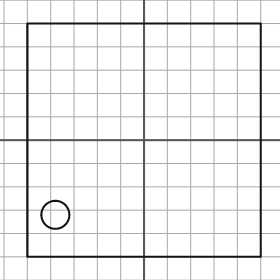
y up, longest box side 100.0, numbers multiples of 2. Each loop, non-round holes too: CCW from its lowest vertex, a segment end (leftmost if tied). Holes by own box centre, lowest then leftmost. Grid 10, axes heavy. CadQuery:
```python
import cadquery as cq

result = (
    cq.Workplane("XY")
    .moveTo(-50.0, -50.0)
    .lineTo(50.0, -50.0)
    .lineTo(50.0, 50.0)
    .lineTo(-50.0, 50.0)
    .close()
    .moveTo(-38.0, -32.0)
    .circle(6.0)
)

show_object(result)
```